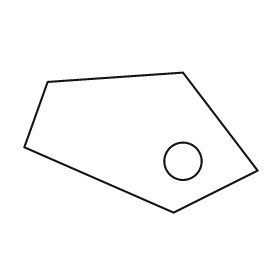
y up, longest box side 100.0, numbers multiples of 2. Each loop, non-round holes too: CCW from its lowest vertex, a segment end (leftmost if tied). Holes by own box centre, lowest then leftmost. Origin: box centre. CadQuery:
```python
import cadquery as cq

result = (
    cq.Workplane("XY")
    .moveTo(14.0, -30.0)
    .lineTo(50.0, -12.0)
    .lineTo(18.0, 30.0)
    .lineTo(-40.0, 26.0)
    .lineTo(-50.0, -2.0)
    .close()
    .moveTo(18.0, -8.0)
    .circle(8.0)
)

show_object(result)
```